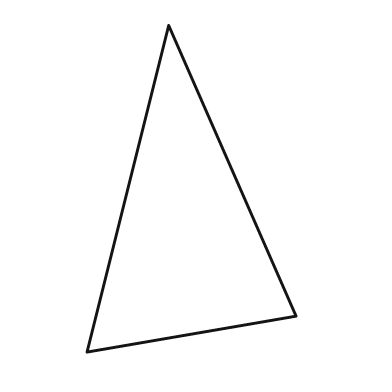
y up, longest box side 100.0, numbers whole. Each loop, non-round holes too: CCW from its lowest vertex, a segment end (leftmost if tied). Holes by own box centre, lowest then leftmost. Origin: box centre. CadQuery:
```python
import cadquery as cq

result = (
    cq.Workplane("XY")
    .moveTo(-32.0, -50.0)
    .lineTo(32.0, -39.0)
    .lineTo(-7.0, 50.0)
    .close()
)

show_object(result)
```